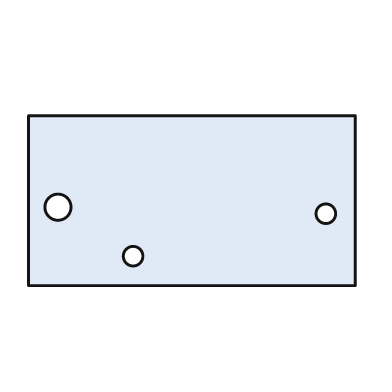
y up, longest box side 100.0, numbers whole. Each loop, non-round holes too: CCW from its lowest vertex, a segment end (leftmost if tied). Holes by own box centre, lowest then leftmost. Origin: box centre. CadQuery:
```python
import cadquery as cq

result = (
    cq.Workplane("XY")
    .moveTo(-50.0, -26.0)
    .lineTo(50.0, -26.0)
    .lineTo(50.0, 26.0)
    .lineTo(-50.0, 26.0)
    .close()
    .moveTo(-18.0, -17.0)
    .circle(3.0)
    .moveTo(41.0, -4.0)
    .circle(3.0)
    .moveTo(-41.0, -2.0)
    .circle(4.0)
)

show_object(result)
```